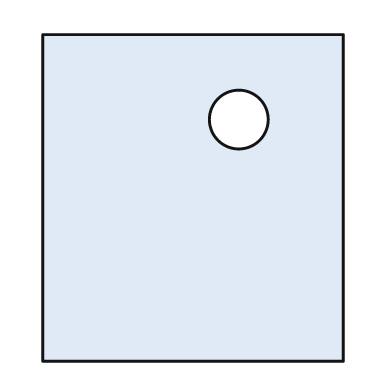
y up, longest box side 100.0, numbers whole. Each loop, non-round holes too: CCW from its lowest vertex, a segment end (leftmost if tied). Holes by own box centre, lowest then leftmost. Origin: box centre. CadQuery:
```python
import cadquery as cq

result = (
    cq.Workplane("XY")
    .moveTo(-46.0, -50.0)
    .lineTo(46.0, -50.0)
    .lineTo(46.0, 50.0)
    .lineTo(-46.0, 50.0)
    .close()
    .moveTo(14.0, 24.0)
    .circle(9.0)
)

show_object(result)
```